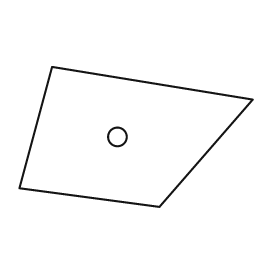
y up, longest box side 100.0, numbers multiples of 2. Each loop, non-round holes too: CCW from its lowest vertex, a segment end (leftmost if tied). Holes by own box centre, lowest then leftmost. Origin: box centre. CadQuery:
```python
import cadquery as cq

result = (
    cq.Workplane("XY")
    .moveTo(10.0, -30.0)
    .lineTo(50.0, 16.0)
    .lineTo(-36.0, 30.0)
    .lineTo(-50.0, -22.0)
    .close()
    .moveTo(-8.0, 0.0)
    .circle(4.0)
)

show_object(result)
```